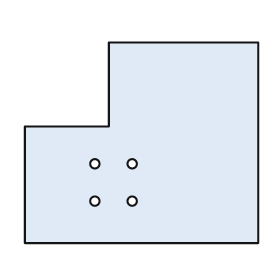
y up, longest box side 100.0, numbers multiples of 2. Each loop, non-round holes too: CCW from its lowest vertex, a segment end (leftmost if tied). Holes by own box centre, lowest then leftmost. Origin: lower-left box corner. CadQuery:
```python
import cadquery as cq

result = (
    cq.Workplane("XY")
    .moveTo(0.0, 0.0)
    .lineTo(100.0, 0.0)
    .lineTo(100.0, 86.0)
    .lineTo(36.0, 86.0)
    .lineTo(36.0, 50.0)
    .lineTo(0.0, 50.0)
    .close()
    .moveTo(30.0, 18.0)
    .circle(2.0)
    .moveTo(46.0, 18.0)
    .circle(2.0)
    .moveTo(30.0, 34.0)
    .circle(2.0)
    .moveTo(46.0, 34.0)
    .circle(2.0)
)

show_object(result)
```